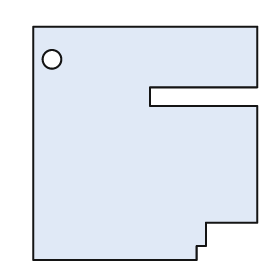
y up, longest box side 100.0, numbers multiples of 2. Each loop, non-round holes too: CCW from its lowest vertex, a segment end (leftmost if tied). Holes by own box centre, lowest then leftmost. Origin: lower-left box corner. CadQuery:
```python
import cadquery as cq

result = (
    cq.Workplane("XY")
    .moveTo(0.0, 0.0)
    .lineTo(70.0, 0.0)
    .lineTo(70.0, 6.0)
    .lineTo(74.0, 6.0)
    .lineTo(74.0, 16.0)
    .lineTo(96.0, 16.0)
    .lineTo(96.0, 66.0)
    .lineTo(50.0, 66.0)
    .lineTo(50.0, 74.0)
    .lineTo(96.0, 74.0)
    .lineTo(96.0, 100.0)
    .lineTo(0.0, 100.0)
    .close()
    .moveTo(8.0, 86.0)
    .circle(4.0)
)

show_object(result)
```